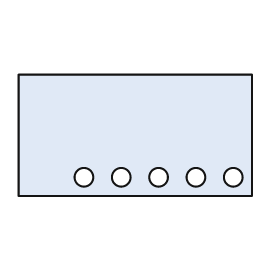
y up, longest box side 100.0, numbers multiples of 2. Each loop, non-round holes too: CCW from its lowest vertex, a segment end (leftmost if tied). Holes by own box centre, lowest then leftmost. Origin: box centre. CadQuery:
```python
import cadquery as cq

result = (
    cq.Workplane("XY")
    .moveTo(-50.0, -26.0)
    .lineTo(50.0, -26.0)
    .lineTo(50.0, 26.0)
    .lineTo(-50.0, 26.0)
    .close()
    .moveTo(-22.0, -18.0)
    .circle(4.0)
    .moveTo(-6.0, -18.0)
    .circle(4.0)
    .moveTo(10.0, -18.0)
    .circle(4.0)
    .moveTo(26.0, -18.0)
    .circle(4.0)
    .moveTo(42.0, -18.0)
    .circle(4.0)
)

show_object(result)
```